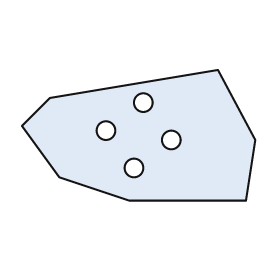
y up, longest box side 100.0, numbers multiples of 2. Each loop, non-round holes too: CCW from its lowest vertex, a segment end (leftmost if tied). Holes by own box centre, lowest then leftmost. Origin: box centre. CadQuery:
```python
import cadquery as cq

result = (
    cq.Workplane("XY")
    .moveTo(-4.0, -28.0)
    .lineTo(46.0, -28.0)
    .lineTo(50.0, -2.0)
    .lineTo(34.0, 28.0)
    .lineTo(-38.0, 16.0)
    .lineTo(-50.0, 4.0)
    .lineTo(-34.0, -18.0)
    .close()
    .moveTo(-2.0, -14.0)
    .circle(4.0)
    .moveTo(14.0, -2.0)
    .circle(4.0)
    .moveTo(-14.0, 2.0)
    .circle(4.0)
    .moveTo(2.0, 14.0)
    .circle(4.0)
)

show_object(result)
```